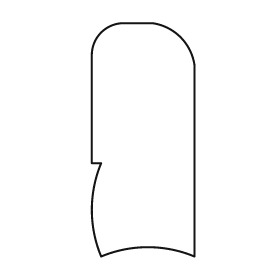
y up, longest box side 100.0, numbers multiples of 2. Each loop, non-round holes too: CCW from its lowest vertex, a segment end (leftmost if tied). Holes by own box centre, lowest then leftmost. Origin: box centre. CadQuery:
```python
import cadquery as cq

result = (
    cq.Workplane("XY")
    .moveTo(-18.0, -50.0)
    .threePointArc((2.0, -46.0), (22.0, -50.0))
    .lineTo(22.0, 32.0)
    .threePointArc((16.0, 44.0), (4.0, 50.0))
    .lineTo(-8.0, 50.0)
    .threePointArc((-18.0, 46.0), (-22.0, 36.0))
    .lineTo(-22.0, -10.0)
    .lineTo(-18.0, -10.0)
    .threePointArc((-22.0, -30.0), (-18.0, -50.0))
    .close()
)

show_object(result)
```